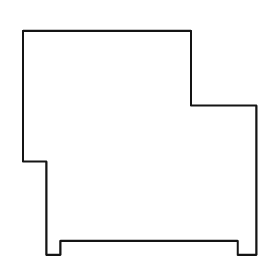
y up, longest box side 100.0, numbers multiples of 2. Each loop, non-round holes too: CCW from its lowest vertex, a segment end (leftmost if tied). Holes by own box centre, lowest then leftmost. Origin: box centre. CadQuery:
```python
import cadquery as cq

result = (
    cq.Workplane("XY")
    .moveTo(-40.0, -48.0)
    .lineTo(-34.0, -48.0)
    .lineTo(-34.0, -42.0)
    .lineTo(42.0, -42.0)
    .lineTo(42.0, -48.0)
    .lineTo(50.0, -48.0)
    .lineTo(50.0, 16.0)
    .lineTo(22.0, 16.0)
    .lineTo(22.0, 48.0)
    .lineTo(-50.0, 48.0)
    .lineTo(-50.0, -8.0)
    .lineTo(-40.0, -8.0)
    .close()
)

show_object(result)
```